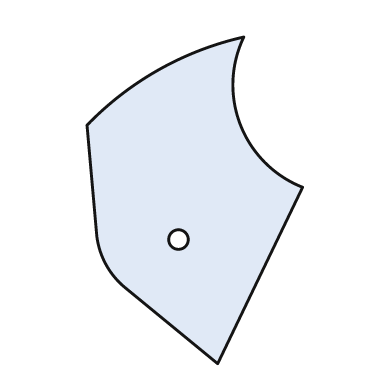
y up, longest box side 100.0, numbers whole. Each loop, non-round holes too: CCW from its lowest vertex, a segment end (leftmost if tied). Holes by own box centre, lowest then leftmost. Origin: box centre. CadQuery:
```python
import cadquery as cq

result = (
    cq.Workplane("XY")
    .moveTo(7.0, -50.0)
    .lineTo(33.0, 4.0)
    .threePointArc((14.0, 23.0), (15.0, 50.0))
    .threePointArc((-11.0, 40.0), (-33.0, 23.0))
    .lineTo(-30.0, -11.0)
    .threePointArc((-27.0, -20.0), (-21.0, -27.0))
    .close()
    .moveTo(-5.0, -12.0)
    .circle(3.0)
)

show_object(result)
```